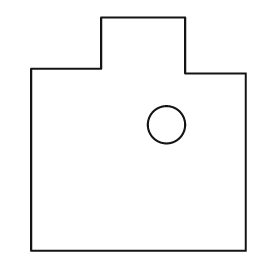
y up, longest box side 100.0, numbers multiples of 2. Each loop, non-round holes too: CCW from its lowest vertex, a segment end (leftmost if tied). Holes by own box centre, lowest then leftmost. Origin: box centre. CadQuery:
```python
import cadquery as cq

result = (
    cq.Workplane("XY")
    .moveTo(-46.0, -50.0)
    .lineTo(46.0, -50.0)
    .lineTo(46.0, 26.0)
    .lineTo(20.0, 26.0)
    .lineTo(20.0, 50.0)
    .lineTo(-16.0, 50.0)
    .lineTo(-16.0, 28.0)
    .lineTo(-46.0, 28.0)
    .close()
    .moveTo(12.0, 4.0)
    .circle(8.0)
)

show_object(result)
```